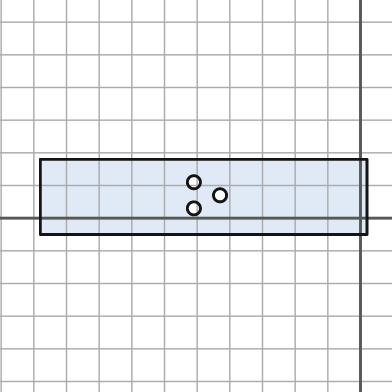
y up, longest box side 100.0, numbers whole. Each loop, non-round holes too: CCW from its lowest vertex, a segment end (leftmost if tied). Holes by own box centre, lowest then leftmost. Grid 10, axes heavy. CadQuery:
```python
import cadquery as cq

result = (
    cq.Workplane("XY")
    .moveTo(-98.0, -5.0)
    .lineTo(2.0, -5.0)
    .lineTo(2.0, 18.0)
    .lineTo(-98.0, 18.0)
    .close()
    .moveTo(-51.0, 3.0)
    .circle(2.0)
    .moveTo(-43.0, 7.0)
    .circle(2.0)
    .moveTo(-51.0, 11.0)
    .circle(2.0)
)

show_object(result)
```